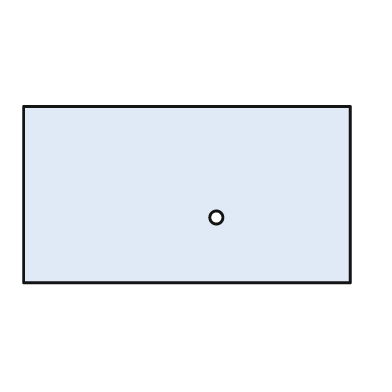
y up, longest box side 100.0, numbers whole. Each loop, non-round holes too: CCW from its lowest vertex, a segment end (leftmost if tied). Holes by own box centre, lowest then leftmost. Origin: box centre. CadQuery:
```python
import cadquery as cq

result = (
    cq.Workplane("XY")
    .moveTo(-50.0, -27.0)
    .lineTo(50.0, -27.0)
    .lineTo(50.0, 27.0)
    .lineTo(-50.0, 27.0)
    .close()
    .moveTo(9.0, -7.0)
    .circle(2.0)
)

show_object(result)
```